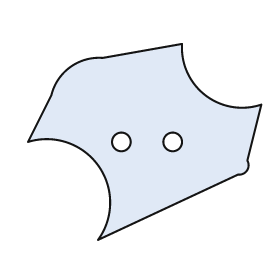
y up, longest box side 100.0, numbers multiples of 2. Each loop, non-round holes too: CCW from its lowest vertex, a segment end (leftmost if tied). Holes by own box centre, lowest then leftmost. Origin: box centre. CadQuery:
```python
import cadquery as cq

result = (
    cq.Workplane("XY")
    .moveTo(-20.0, -42.0)
    .lineTo(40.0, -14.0)
    .threePointArc((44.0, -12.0), (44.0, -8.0))
    .lineTo(50.0, 16.0)
    .threePointArc((26.0, 20.0), (16.0, 42.0))
    .lineTo(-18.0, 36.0)
    .threePointArc((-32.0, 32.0), (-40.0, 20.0))
    .lineTo(-50.0, 0.0)
    .threePointArc((-20.0, -10.0), (-20.0, -42.0))
    .close()
    .moveTo(-10.0, 0.0)
    .circle(4.0)
    .moveTo(12.0, 0.0)
    .circle(4.0)
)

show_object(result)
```